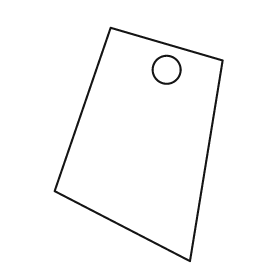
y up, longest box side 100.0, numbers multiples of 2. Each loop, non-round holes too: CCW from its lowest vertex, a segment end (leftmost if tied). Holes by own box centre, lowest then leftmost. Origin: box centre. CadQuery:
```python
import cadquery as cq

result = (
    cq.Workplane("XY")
    .moveTo(22.0, -50.0)
    .lineTo(36.0, 36.0)
    .lineTo(-12.0, 50.0)
    .lineTo(-36.0, -20.0)
    .close()
    .moveTo(12.0, 32.0)
    .circle(6.0)
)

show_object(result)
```